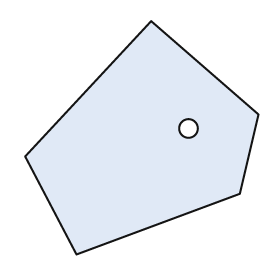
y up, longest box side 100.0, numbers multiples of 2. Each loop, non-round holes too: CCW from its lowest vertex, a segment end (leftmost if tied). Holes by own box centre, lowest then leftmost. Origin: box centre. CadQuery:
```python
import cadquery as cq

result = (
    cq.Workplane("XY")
    .moveTo(-28.0, -50.0)
    .lineTo(42.0, -24.0)
    .lineTo(50.0, 10.0)
    .lineTo(4.0, 50.0)
    .lineTo(-50.0, -8.0)
    .close()
    .moveTo(20.0, 4.0)
    .circle(4.0)
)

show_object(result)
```